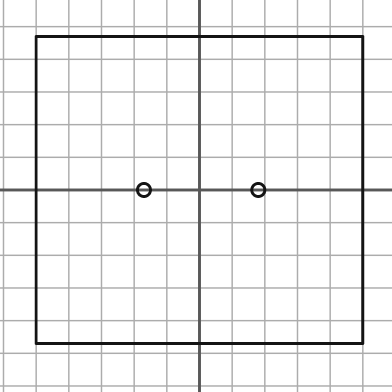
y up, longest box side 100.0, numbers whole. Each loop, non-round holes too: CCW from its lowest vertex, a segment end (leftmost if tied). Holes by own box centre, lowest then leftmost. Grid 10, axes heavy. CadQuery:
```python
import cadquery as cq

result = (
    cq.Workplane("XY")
    .moveTo(-50.0, -47.0)
    .lineTo(50.0, -47.0)
    .lineTo(50.0, 47.0)
    .lineTo(-50.0, 47.0)
    .close()
    .moveTo(-17.0, 0.0)
    .circle(2.0)
    .moveTo(18.0, 0.0)
    .circle(2.0)
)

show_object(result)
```